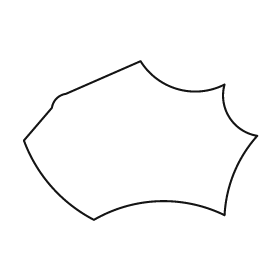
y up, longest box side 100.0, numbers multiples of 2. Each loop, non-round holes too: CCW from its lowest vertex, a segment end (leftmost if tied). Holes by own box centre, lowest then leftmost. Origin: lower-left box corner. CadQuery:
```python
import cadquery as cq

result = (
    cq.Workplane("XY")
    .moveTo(30.0, 0.0)
    .threePointArc((58.0, 8.0), (86.0, 2.0))
    .threePointArc((90.0, 20.0), (100.0, 36.0))
    .threePointArc((88.0, 44.0), (86.0, 58.0))
    .threePointArc((66.0, 56.0), (50.0, 68.0))
    .lineTo(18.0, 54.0)
    .threePointArc((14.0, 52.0), (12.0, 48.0))
    .lineTo(0.0, 34.0)
    .threePointArc((12.0, 14.0), (30.0, 0.0))
    .close()
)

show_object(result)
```